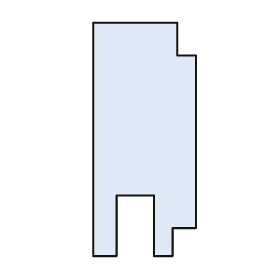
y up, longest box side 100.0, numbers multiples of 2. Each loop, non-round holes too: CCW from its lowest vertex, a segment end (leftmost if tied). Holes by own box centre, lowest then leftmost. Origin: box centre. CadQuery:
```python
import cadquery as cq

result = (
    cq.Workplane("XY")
    .moveTo(-22.0, -50.0)
    .lineTo(-12.0, -50.0)
    .lineTo(-12.0, -24.0)
    .lineTo(4.0, -24.0)
    .lineTo(4.0, -50.0)
    .lineTo(12.0, -50.0)
    .lineTo(12.0, -38.0)
    .lineTo(22.0, -38.0)
    .lineTo(22.0, 36.0)
    .lineTo(14.0, 36.0)
    .lineTo(14.0, 50.0)
    .lineTo(-22.0, 50.0)
    .close()
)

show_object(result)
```